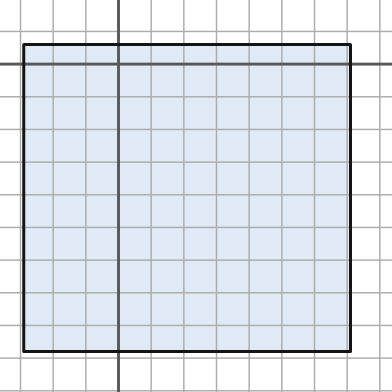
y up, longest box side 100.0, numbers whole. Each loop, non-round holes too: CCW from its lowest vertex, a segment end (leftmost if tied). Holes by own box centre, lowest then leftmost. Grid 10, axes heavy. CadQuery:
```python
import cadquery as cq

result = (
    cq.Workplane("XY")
    .moveTo(-29.0, -88.0)
    .lineTo(71.0, -88.0)
    .lineTo(71.0, 6.0)
    .lineTo(-29.0, 6.0)
    .close()
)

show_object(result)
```